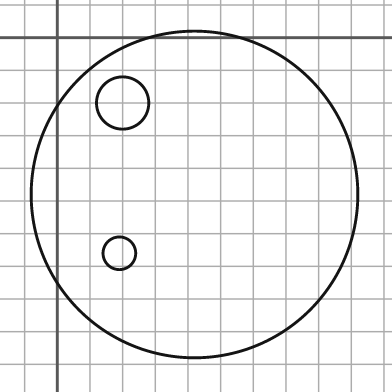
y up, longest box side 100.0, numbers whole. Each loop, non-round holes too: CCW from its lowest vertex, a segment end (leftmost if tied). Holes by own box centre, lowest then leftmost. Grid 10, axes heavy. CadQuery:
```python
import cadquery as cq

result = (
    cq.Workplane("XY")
    .moveTo(42.0, -48.0)
    .circle(50.0)
    .moveTo(19.0, -66.0)
    .circle(5.0)
    .moveTo(20.0, -20.0)
    .circle(8.0)
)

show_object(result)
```